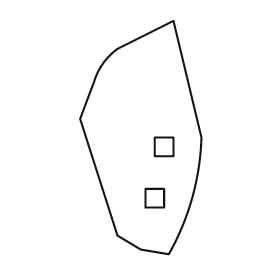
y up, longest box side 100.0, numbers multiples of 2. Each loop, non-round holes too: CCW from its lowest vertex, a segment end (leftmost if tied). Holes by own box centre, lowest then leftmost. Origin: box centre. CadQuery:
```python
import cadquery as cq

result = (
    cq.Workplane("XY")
    .moveTo(12.0, -50.0)
    .threePointArc((22.0, -26.0), (26.0, 0.0))
    .lineTo(14.0, 50.0)
    .lineTo(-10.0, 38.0)
    .threePointArc((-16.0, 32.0), (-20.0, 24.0))
    .lineTo(-26.0, 8.0)
    .lineTo(-10.0, -42.0)
    .lineTo(0.0, -48.0)
    .close()
    .moveTo(2.0, -30.0)
    .lineTo(10.0, -30.0)
    .lineTo(10.0, -22.0)
    .lineTo(2.0, -22.0)
    .close()
    .moveTo(6.0, -8.0)
    .lineTo(14.0, -8.0)
    .lineTo(14.0, 0.0)
    .lineTo(6.0, 0.0)
    .close()
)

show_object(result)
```